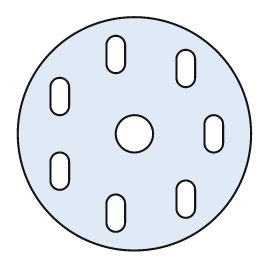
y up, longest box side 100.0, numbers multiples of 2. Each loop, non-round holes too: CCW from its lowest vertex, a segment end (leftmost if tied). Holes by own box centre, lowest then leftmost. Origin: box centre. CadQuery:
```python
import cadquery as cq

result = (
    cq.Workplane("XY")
    .moveTo(0.0, 0.0)
    .circle(50.0)
    .moveTo(-12.0, -38.0)
    .threePointArc((-8.0, -42.0), (-4.0, -38.0))
    .lineTo(-4.0, -30.0)
    .threePointArc((-8.0, -26.0), (-12.0, -30.0))
    .close()
    .moveTo(18.0, -32.0)
    .threePointArc((22.0, -36.0), (26.0, -32.0))
    .lineTo(26.0, -24.0)
    .threePointArc((22.0, -20.0), (18.0, -24.0))
    .close()
    .moveTo(-36.0, -20.0)
    .threePointArc((-32.0, -24.0), (-28.0, -20.0))
    .lineTo(-28.0, -12.0)
    .threePointArc((-32.0, -8.0), (-36.0, -12.0))
    .close()
    .moveTo(0.0, 0.0)
    .circle(8.0)
    .moveTo(30.0, -4.0)
    .threePointArc((34.0, -8.0), (38.0, -4.0))
    .lineTo(38.0, 4.0)
    .threePointArc((34.0, 8.0), (30.0, 4.0))
    .close()
    .moveTo(-36.0, 12.0)
    .threePointArc((-32.0, 8.0), (-28.0, 12.0))
    .lineTo(-28.0, 20.0)
    .threePointArc((-32.0, 24.0), (-36.0, 20.0))
    .close()
    .moveTo(18.0, 24.0)
    .threePointArc((22.0, 20.0), (26.0, 24.0))
    .lineTo(26.0, 32.0)
    .threePointArc((22.0, 36.0), (18.0, 32.0))
    .close()
    .moveTo(-12.0, 30.0)
    .threePointArc((-8.0, 26.0), (-4.0, 30.0))
    .lineTo(-4.0, 38.0)
    .threePointArc((-8.0, 42.0), (-12.0, 38.0))
    .close()
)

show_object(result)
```